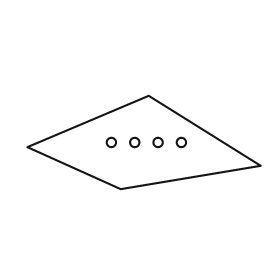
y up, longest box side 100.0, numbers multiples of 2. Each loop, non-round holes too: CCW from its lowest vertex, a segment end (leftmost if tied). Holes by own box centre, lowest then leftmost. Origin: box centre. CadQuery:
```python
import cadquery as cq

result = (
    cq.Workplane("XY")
    .moveTo(-10.0, -20.0)
    .lineTo(50.0, -10.0)
    .lineTo(2.0, 20.0)
    .lineTo(-50.0, -2.0)
    .close()
    .moveTo(-14.0, 0.0)
    .circle(2.0)
    .moveTo(-4.0, 0.0)
    .circle(2.0)
    .moveTo(6.0, 0.0)
    .circle(2.0)
    .moveTo(16.0, 0.0)
    .circle(2.0)
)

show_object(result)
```